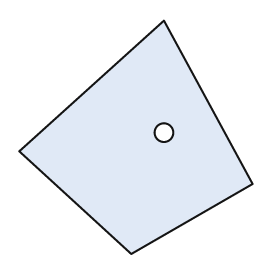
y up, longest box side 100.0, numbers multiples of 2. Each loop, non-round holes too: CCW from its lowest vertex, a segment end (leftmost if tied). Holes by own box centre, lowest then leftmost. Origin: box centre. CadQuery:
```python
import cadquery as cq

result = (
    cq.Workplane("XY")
    .moveTo(-2.0, -50.0)
    .lineTo(50.0, -20.0)
    .lineTo(12.0, 50.0)
    .lineTo(-50.0, -6.0)
    .close()
    .moveTo(12.0, 2.0)
    .circle(4.0)
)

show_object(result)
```